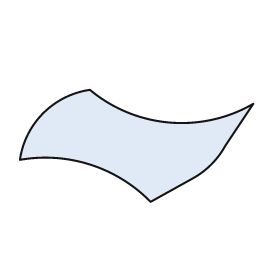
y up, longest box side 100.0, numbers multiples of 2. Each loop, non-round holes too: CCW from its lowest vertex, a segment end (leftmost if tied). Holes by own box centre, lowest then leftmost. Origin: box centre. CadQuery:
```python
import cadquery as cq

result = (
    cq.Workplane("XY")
    .moveTo(6.0, -24.0)
    .lineTo(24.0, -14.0)
    .threePointArc((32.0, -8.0), (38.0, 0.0))
    .lineTo(50.0, 18.0)
    .threePointArc((14.0, 10.0), (-20.0, 24.0))
    .threePointArc((-40.0, 14.0), (-50.0, -6.0))
    .threePointArc((-20.0, -8.0), (6.0, -24.0))
    .close()
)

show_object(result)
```